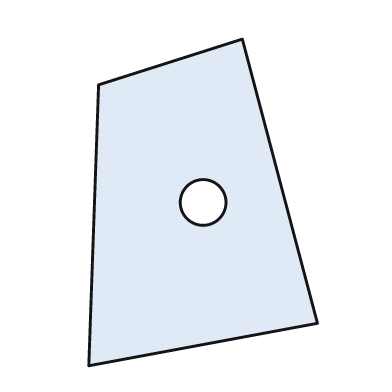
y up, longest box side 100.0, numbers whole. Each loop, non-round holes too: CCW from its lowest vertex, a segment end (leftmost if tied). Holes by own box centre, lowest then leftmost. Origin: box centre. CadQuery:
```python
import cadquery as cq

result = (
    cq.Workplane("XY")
    .moveTo(-35.0, -50.0)
    .lineTo(35.0, -37.0)
    .lineTo(12.0, 50.0)
    .lineTo(-32.0, 36.0)
    .close()
    .moveTo(0.0, 0.0)
    .circle(7.0)
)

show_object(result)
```